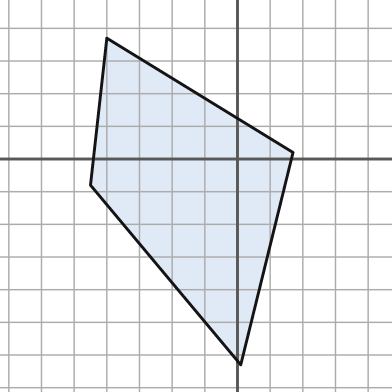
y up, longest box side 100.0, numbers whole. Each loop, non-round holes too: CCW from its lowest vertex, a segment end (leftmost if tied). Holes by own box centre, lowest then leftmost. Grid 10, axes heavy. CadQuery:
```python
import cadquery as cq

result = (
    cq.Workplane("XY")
    .moveTo(1.0, -63.0)
    .lineTo(17.0, 2.0)
    .lineTo(-40.0, 37.0)
    .lineTo(-45.0, -8.0)
    .close()
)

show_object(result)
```